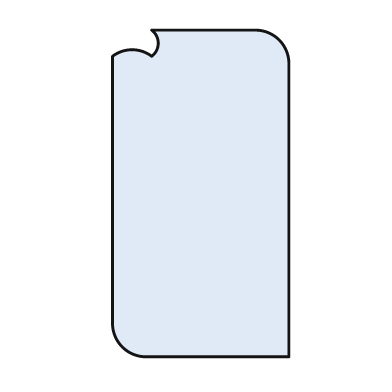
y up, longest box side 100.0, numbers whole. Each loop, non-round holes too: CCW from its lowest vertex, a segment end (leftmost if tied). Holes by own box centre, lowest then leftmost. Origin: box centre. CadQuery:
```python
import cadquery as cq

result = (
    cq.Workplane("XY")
    .moveTo(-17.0, -50.0)
    .lineTo(27.0, -50.0)
    .lineTo(27.0, 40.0)
    .threePointArc((24.0, 47.0), (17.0, 50.0))
    .lineTo(-15.0, 50.0)
    .threePointArc((-13.0, 46.0), (-15.0, 42.0))
    .threePointArc((-21.0, 44.0), (-27.0, 42.0))
    .lineTo(-27.0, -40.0)
    .threePointArc((-24.0, -47.0), (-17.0, -50.0))
    .close()
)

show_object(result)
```